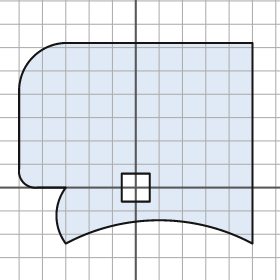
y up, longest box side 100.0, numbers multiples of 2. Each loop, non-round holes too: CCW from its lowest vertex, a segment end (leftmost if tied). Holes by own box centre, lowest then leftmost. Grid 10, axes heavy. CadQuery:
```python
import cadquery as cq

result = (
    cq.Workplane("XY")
    .moveTo(-30.0, -24.0)
    .threePointArc((10.0, -14.0), (50.0, -24.0))
    .lineTo(50.0, 62.0)
    .lineTo(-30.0, 62.0)
    .threePointArc((-44.0, 56.0), (-50.0, 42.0))
    .lineTo(-50.0, 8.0)
    .threePointArc((-48.0, 2.0), (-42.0, 0.0))
    .lineTo(-30.0, 0.0)
    .threePointArc((-34.0, -12.0), (-30.0, -24.0))
    .close()
    .moveTo(-6.0, -6.0)
    .lineTo(6.0, -6.0)
    .lineTo(6.0, 6.0)
    .lineTo(-6.0, 6.0)
    .close()
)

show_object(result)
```